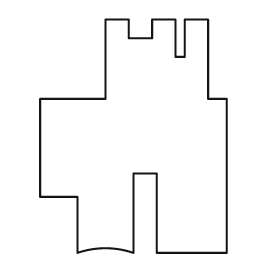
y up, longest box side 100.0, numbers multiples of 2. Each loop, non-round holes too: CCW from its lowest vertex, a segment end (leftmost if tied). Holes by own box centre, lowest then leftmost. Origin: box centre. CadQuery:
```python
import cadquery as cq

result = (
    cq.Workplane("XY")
    .moveTo(-24.0, -50.0)
    .threePointArc((-12.0, -48.0), (0.0, -50.0))
    .lineTo(0.0, -16.0)
    .lineTo(10.0, -16.0)
    .lineTo(10.0, -50.0)
    .lineTo(40.0, -50.0)
    .lineTo(40.0, 16.0)
    .lineTo(32.0, 16.0)
    .lineTo(32.0, 50.0)
    .lineTo(22.0, 50.0)
    .lineTo(22.0, 34.0)
    .lineTo(18.0, 34.0)
    .lineTo(18.0, 50.0)
    .lineTo(8.0, 50.0)
    .lineTo(8.0, 42.0)
    .lineTo(-2.0, 42.0)
    .lineTo(-2.0, 50.0)
    .lineTo(-12.0, 50.0)
    .lineTo(-12.0, 16.0)
    .lineTo(-40.0, 16.0)
    .lineTo(-40.0, -26.0)
    .lineTo(-24.0, -26.0)
    .close()
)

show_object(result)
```